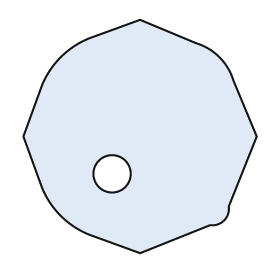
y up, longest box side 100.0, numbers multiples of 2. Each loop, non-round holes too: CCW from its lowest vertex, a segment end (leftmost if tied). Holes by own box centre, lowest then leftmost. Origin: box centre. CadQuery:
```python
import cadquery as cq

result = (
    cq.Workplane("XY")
    .moveTo(0.0, -50.0)
    .lineTo(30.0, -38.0)
    .threePointArc((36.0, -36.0), (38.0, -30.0))
    .lineTo(50.0, 0.0)
    .lineTo(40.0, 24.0)
    .threePointArc((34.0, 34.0), (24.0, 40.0))
    .lineTo(0.0, 50.0)
    .lineTo(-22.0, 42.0)
    .threePointArc((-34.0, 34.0), (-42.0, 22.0))
    .lineTo(-50.0, 0.0)
    .lineTo(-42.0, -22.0)
    .threePointArc((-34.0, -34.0), (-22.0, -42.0))
    .close()
    .moveTo(-12.0, -16.0)
    .circle(8.0)
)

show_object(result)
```